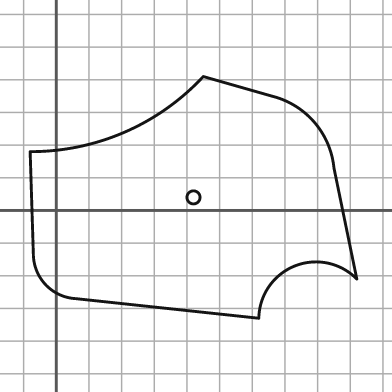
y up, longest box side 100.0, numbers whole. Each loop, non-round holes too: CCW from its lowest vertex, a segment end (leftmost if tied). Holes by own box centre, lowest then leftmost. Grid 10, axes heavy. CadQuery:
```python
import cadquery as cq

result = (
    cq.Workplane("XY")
    .moveTo(62.0, -33.0)
    .threePointArc((73.0, -17.0), (92.0, -21.0))
    .lineTo(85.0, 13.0)
    .threePointArc((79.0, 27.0), (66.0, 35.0))
    .lineTo(45.0, 41.0)
    .threePointArc((21.0, 24.0), (-8.0, 18.0))
    .lineTo(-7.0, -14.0)
    .threePointArc((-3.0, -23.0), (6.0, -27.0))
    .close()
    .moveTo(42.0, 4.0)
    .circle(2.0)
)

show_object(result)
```